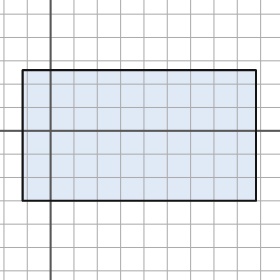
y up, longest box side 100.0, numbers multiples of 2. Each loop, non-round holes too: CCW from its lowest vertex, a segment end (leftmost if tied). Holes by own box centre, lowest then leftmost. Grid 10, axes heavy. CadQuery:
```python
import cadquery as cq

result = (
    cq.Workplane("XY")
    .moveTo(-12.0, -30.0)
    .lineTo(88.0, -30.0)
    .lineTo(88.0, 26.0)
    .lineTo(-12.0, 26.0)
    .close()
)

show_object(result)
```